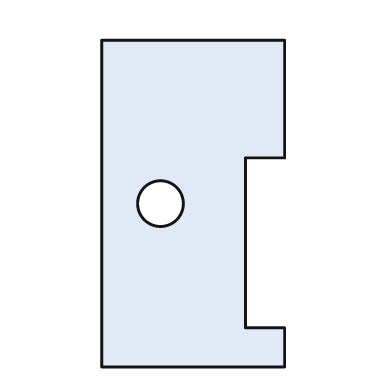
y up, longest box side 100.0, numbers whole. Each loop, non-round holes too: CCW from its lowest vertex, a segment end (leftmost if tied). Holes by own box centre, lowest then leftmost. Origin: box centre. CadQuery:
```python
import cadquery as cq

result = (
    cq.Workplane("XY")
    .moveTo(-28.0, -50.0)
    .lineTo(28.0, -50.0)
    .lineTo(28.0, -38.0)
    .lineTo(16.0, -38.0)
    .lineTo(16.0, 14.0)
    .lineTo(28.0, 14.0)
    .lineTo(28.0, 50.0)
    .lineTo(-28.0, 50.0)
    .close()
    .moveTo(-10.0, 0.0)
    .circle(7.0)
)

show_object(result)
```